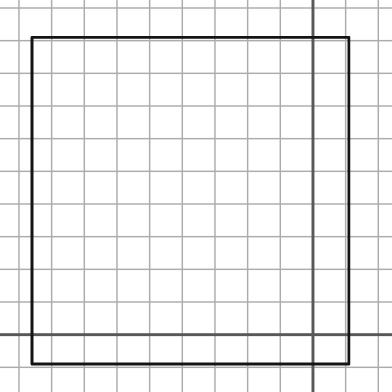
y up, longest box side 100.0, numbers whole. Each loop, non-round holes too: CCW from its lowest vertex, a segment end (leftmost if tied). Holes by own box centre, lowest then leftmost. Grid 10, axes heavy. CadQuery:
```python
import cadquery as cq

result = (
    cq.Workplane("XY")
    .moveTo(-86.0, -9.0)
    .lineTo(11.0, -9.0)
    .lineTo(11.0, 91.0)
    .lineTo(-86.0, 91.0)
    .close()
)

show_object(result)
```